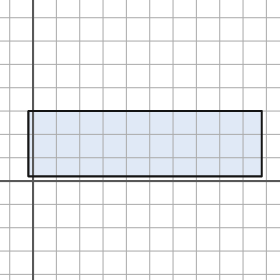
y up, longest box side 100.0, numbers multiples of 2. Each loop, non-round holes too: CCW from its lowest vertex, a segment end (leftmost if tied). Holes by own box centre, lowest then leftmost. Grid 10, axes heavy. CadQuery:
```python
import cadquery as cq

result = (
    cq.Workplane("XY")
    .moveTo(-2.0, 2.0)
    .lineTo(98.0, 2.0)
    .lineTo(98.0, 30.0)
    .lineTo(-2.0, 30.0)
    .close()
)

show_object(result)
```